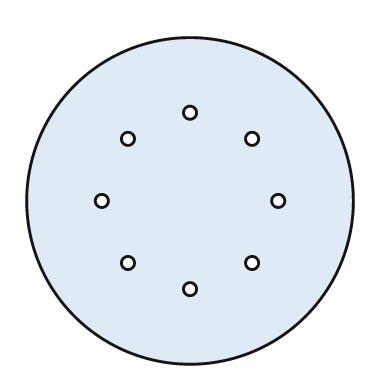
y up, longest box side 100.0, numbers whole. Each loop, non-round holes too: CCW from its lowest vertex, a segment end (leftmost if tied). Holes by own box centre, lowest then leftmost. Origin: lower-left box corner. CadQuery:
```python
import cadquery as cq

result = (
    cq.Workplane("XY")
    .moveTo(50.0, 50.0)
    .circle(50.0)
    .moveTo(50.0, 23.0)
    .circle(2.0)
    .moveTo(31.0, 31.0)
    .circle(2.0)
    .moveTo(69.0, 31.0)
    .circle(2.0)
    .moveTo(23.0, 50.0)
    .circle(2.0)
    .moveTo(77.0, 50.0)
    .circle(2.0)
    .moveTo(31.0, 69.0)
    .circle(2.0)
    .moveTo(69.0, 69.0)
    .circle(2.0)
    .moveTo(50.0, 77.0)
    .circle(2.0)
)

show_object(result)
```